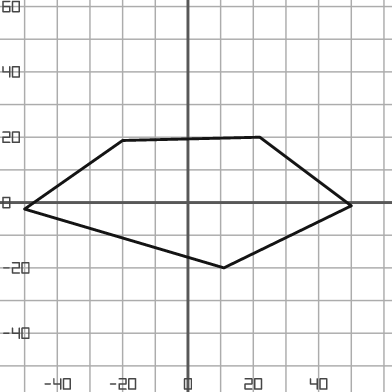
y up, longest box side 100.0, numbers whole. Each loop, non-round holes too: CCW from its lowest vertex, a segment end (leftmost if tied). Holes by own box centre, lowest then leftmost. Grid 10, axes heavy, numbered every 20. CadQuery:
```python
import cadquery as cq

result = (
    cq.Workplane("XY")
    .moveTo(11.0, -20.0)
    .lineTo(50.0, -1.0)
    .lineTo(22.0, 20.0)
    .lineTo(-20.0, 19.0)
    .lineTo(-50.0, -2.0)
    .close()
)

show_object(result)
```